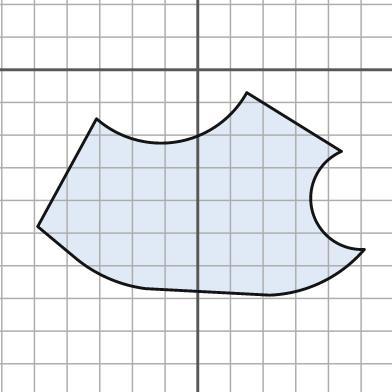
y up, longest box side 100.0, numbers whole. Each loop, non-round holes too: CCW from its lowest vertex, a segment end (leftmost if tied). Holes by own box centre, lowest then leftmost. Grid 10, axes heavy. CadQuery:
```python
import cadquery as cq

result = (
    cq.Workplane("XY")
    .moveTo(22.0, -69.0)
    .threePointArc((38.0, -65.0), (51.0, -55.0))
    .threePointArc((35.0, -43.0), (44.0, -25.0))
    .lineTo(15.0, -7.0)
    .threePointArc((-6.0, -22.0), (-31.0, -15.0))
    .lineTo(-49.0, -48.0)
    .lineTo(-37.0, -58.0)
    .threePointArc((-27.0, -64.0), (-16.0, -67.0))
    .close()
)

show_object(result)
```